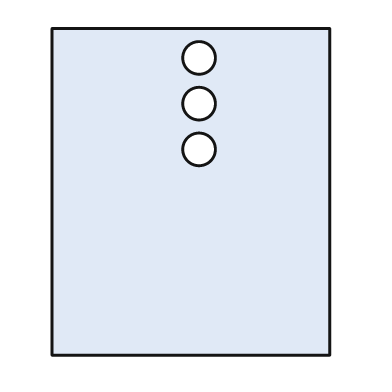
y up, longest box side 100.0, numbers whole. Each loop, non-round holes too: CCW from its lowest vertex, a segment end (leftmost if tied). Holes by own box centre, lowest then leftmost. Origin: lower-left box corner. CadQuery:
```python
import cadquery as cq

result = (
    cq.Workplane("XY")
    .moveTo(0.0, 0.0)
    .lineTo(85.0, 0.0)
    .lineTo(85.0, 100.0)
    .lineTo(0.0, 100.0)
    .close()
    .moveTo(45.0, 63.0)
    .circle(5.0)
    .moveTo(45.0, 77.0)
    .circle(5.0)
    .moveTo(45.0, 91.0)
    .circle(5.0)
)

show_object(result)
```